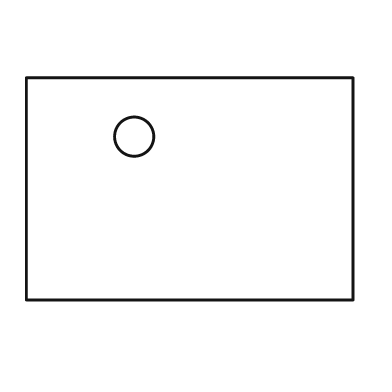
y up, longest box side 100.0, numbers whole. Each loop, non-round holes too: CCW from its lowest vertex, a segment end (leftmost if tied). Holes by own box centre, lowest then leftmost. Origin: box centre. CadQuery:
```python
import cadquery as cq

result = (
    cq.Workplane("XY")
    .moveTo(-50.0, -34.0)
    .lineTo(50.0, -34.0)
    .lineTo(50.0, 34.0)
    .lineTo(-50.0, 34.0)
    .close()
    .moveTo(-17.0, 16.0)
    .circle(6.0)
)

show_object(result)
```